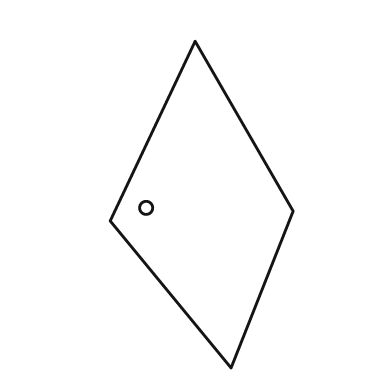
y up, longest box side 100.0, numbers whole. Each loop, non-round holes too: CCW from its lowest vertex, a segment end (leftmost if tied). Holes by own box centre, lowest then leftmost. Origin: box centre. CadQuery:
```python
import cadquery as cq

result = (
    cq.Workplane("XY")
    .moveTo(9.0, -50.0)
    .lineTo(28.0, -2.0)
    .lineTo(-2.0, 50.0)
    .lineTo(-28.0, -5.0)
    .close()
    .moveTo(-17.0, -1.0)
    .circle(2.0)
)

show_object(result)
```